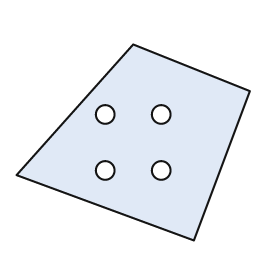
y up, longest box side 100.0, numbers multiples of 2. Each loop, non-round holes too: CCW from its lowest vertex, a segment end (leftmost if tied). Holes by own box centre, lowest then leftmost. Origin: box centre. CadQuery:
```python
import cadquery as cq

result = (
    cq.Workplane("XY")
    .moveTo(26.0, -42.0)
    .lineTo(50.0, 22.0)
    .lineTo(0.0, 42.0)
    .lineTo(-50.0, -14.0)
    .close()
    .moveTo(-12.0, -12.0)
    .circle(4.0)
    .moveTo(12.0, -12.0)
    .circle(4.0)
    .moveTo(-12.0, 12.0)
    .circle(4.0)
    .moveTo(12.0, 12.0)
    .circle(4.0)
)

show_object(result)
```